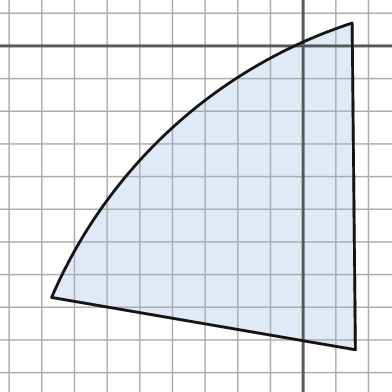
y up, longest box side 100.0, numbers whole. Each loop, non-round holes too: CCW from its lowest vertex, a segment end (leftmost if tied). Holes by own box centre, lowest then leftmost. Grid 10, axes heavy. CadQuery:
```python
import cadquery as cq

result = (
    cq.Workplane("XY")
    .moveTo(16.0, -93.0)
    .lineTo(15.0, 7.0)
    .threePointArc((-40.0, -25.0), (-77.0, -77.0))
    .close()
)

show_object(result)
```